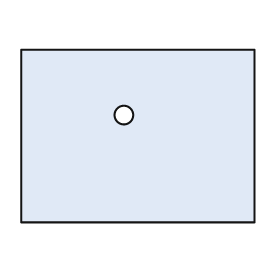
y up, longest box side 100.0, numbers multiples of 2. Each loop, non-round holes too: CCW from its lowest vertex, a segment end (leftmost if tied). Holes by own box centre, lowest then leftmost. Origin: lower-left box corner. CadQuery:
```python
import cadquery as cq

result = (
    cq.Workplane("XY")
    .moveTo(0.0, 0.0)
    .lineTo(100.0, 0.0)
    .lineTo(100.0, 74.0)
    .lineTo(0.0, 74.0)
    .close()
    .moveTo(44.0, 46.0)
    .circle(4.0)
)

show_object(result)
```